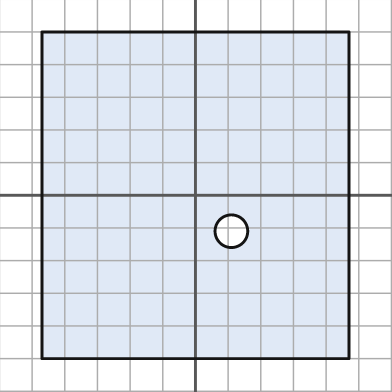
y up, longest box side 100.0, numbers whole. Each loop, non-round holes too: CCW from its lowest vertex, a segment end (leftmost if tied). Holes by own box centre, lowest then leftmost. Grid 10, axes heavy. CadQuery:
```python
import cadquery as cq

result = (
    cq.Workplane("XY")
    .moveTo(-47.0, -50.0)
    .lineTo(47.0, -50.0)
    .lineTo(47.0, 50.0)
    .lineTo(-47.0, 50.0)
    .close()
    .moveTo(11.0, -11.0)
    .circle(5.0)
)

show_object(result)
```